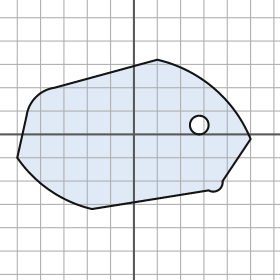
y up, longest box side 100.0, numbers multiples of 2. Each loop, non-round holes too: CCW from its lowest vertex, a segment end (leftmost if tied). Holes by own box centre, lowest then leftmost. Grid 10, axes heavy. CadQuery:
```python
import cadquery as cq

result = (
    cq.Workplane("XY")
    .moveTo(-18.0, -32.0)
    .lineTo(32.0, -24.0)
    .threePointArc((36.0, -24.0), (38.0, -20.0))
    .lineTo(50.0, -2.0)
    .threePointArc((34.0, 20.0), (10.0, 32.0))
    .lineTo(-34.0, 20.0)
    .threePointArc((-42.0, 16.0), (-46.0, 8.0))
    .lineTo(-50.0, -10.0)
    .threePointArc((-36.0, -24.0), (-18.0, -32.0))
    .close()
    .moveTo(28.0, 4.0)
    .circle(4.0)
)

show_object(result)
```